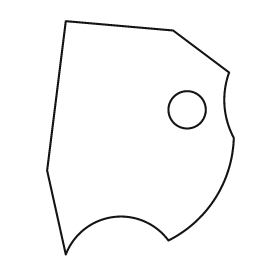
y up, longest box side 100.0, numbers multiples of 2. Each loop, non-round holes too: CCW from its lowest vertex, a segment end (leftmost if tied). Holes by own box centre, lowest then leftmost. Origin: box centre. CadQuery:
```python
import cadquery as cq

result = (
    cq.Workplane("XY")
    .moveTo(-32.0, -50.0)
    .threePointArc((-12.0, -34.0), (12.0, -44.0))
    .threePointArc((32.0, -26.0), (40.0, 0.0))
    .threePointArc((36.0, 14.0), (38.0, 28.0))
    .lineTo(14.0, 46.0)
    .lineTo(-32.0, 50.0)
    .lineTo(-40.0, -14.0)
    .close()
    .moveTo(20.0, 12.0)
    .circle(8.0)
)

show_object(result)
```